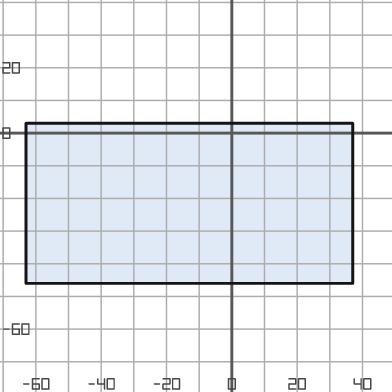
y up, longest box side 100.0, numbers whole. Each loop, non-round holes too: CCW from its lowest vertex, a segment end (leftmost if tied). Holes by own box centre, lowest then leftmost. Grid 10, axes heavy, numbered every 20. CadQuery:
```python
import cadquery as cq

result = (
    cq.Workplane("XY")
    .moveTo(-63.0, -46.0)
    .lineTo(37.0, -46.0)
    .lineTo(37.0, 3.0)
    .lineTo(-63.0, 3.0)
    .close()
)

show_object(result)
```